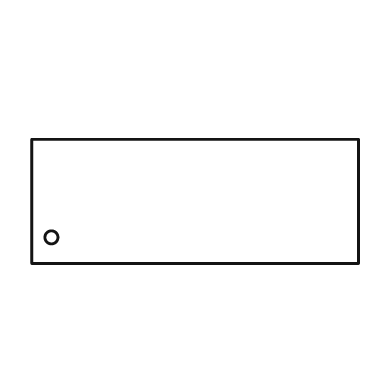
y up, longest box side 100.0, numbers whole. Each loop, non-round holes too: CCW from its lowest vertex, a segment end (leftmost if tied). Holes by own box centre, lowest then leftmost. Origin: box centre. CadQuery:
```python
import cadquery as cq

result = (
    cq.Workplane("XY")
    .moveTo(-50.0, -19.0)
    .lineTo(50.0, -19.0)
    .lineTo(50.0, 19.0)
    .lineTo(-50.0, 19.0)
    .close()
    .moveTo(-44.0, -11.0)
    .circle(2.0)
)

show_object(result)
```